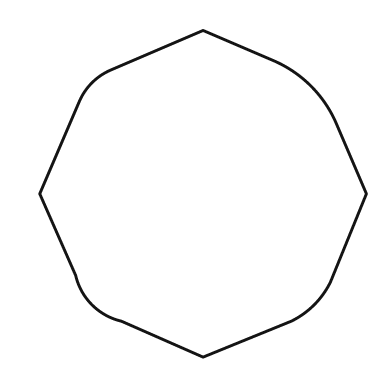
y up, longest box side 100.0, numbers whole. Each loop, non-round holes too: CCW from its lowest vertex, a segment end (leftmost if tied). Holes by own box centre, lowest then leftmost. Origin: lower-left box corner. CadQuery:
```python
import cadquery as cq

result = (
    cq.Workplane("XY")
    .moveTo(50.0, 0.0)
    .lineTo(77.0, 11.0)
    .threePointArc((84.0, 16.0), (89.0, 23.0))
    .lineTo(100.0, 50.0)
    .lineTo(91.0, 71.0)
    .threePointArc((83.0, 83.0), (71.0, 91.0))
    .lineTo(50.0, 100.0)
    .lineTo(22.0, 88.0)
    .threePointArc((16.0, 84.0), (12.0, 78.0))
    .lineTo(0.0, 50.0)
    .lineTo(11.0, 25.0)
    .threePointArc((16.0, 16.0), (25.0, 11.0))
    .close()
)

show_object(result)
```